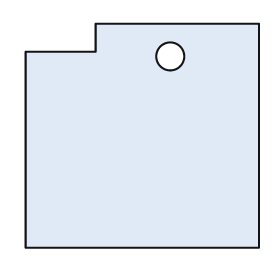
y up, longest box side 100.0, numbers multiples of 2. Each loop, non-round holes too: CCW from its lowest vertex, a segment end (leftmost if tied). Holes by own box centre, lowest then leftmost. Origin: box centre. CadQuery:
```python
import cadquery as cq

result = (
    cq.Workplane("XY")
    .moveTo(-50.0, -48.0)
    .lineTo(50.0, -48.0)
    .lineTo(50.0, 48.0)
    .lineTo(-20.0, 48.0)
    .lineTo(-20.0, 36.0)
    .lineTo(-50.0, 36.0)
    .close()
    .moveTo(12.0, 34.0)
    .circle(6.0)
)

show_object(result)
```